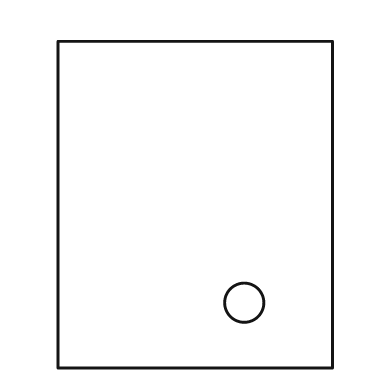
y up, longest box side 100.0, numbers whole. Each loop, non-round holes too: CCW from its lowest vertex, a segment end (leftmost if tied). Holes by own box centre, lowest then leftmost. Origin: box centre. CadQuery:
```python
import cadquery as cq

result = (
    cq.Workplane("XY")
    .moveTo(-42.0, -50.0)
    .lineTo(42.0, -50.0)
    .lineTo(42.0, 50.0)
    .lineTo(-42.0, 50.0)
    .close()
    .moveTo(15.0, -30.0)
    .circle(6.0)
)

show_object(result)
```